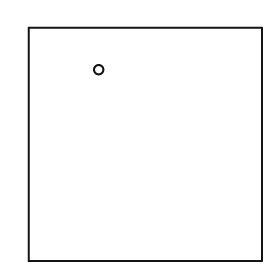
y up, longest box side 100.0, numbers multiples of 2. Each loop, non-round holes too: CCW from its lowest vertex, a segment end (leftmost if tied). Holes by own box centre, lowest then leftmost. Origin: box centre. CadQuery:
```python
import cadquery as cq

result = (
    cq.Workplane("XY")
    .moveTo(-50.0, -50.0)
    .lineTo(50.0, -50.0)
    .lineTo(50.0, 50.0)
    .lineTo(-50.0, 50.0)
    .close()
    .moveTo(-20.0, 32.0)
    .circle(2.0)
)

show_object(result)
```